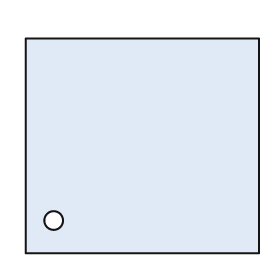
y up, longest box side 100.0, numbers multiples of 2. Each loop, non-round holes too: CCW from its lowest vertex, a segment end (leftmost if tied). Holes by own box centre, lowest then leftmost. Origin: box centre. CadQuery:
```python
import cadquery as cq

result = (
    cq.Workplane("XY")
    .moveTo(-50.0, -46.0)
    .lineTo(50.0, -46.0)
    .lineTo(50.0, 46.0)
    .lineTo(-50.0, 46.0)
    .close()
    .moveTo(-38.0, -32.0)
    .circle(4.0)
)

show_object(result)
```